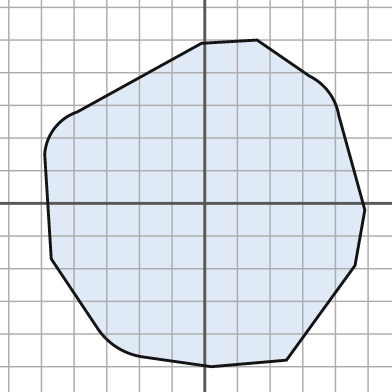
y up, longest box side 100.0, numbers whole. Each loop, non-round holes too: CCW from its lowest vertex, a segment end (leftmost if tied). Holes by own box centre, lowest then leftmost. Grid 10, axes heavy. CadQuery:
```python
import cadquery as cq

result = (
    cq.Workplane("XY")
    .moveTo(2.0, -50.0)
    .lineTo(25.0, -48.0)
    .lineTo(46.0, -19.0)
    .lineTo(49.0, -2.0)
    .lineTo(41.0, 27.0)
    .threePointArc((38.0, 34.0), (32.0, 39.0))
    .lineTo(16.0, 50.0)
    .lineTo(-1.0, 49.0)
    .lineTo(-39.0, 28.0)
    .threePointArc((-46.0, 23.0), (-49.0, 15.0))
    .lineTo(-47.0, -17.0)
    .lineTo(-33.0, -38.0)
    .threePointArc((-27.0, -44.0), (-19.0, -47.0))
    .close()
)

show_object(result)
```